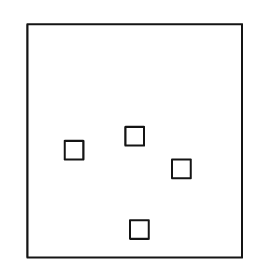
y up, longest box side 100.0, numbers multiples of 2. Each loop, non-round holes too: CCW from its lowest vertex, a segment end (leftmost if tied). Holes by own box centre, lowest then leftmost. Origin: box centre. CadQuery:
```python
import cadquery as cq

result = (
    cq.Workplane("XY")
    .moveTo(-46.0, -50.0)
    .lineTo(46.0, -50.0)
    .lineTo(46.0, 50.0)
    .lineTo(-46.0, 50.0)
    .close()
    .moveTo(-2.0, -42.0)
    .lineTo(6.0, -42.0)
    .lineTo(6.0, -34.0)
    .lineTo(-2.0, -34.0)
    .close()
    .moveTo(16.0, -16.0)
    .lineTo(24.0, -16.0)
    .lineTo(24.0, -8.0)
    .lineTo(16.0, -8.0)
    .close()
    .moveTo(-30.0, -8.0)
    .lineTo(-22.0, -8.0)
    .lineTo(-22.0, 0.0)
    .lineTo(-30.0, 0.0)
    .close()
    .moveTo(-4.0, -2.0)
    .lineTo(4.0, -2.0)
    .lineTo(4.0, 6.0)
    .lineTo(-4.0, 6.0)
    .close()
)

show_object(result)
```